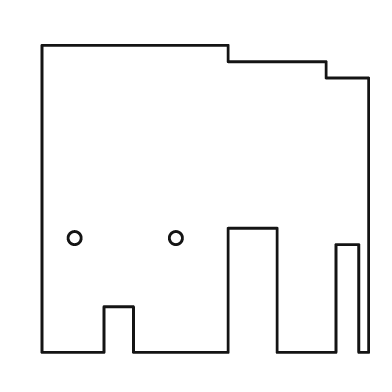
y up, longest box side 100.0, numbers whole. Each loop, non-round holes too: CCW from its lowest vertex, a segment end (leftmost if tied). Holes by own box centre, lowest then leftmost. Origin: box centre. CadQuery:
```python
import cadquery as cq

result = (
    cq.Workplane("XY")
    .moveTo(-50.0, -47.0)
    .lineTo(-31.0, -47.0)
    .lineTo(-31.0, -33.0)
    .lineTo(-22.0, -33.0)
    .lineTo(-22.0, -47.0)
    .lineTo(7.0, -47.0)
    .lineTo(7.0, -9.0)
    .lineTo(22.0, -9.0)
    .lineTo(22.0, -47.0)
    .lineTo(40.0, -47.0)
    .lineTo(40.0, -14.0)
    .lineTo(47.0, -14.0)
    .lineTo(47.0, -47.0)
    .lineTo(50.0, -47.0)
    .lineTo(50.0, 37.0)
    .lineTo(37.0, 37.0)
    .lineTo(37.0, 42.0)
    .lineTo(7.0, 42.0)
    .lineTo(7.0, 47.0)
    .lineTo(-50.0, 47.0)
    .close()
    .moveTo(-40.0, -12.0)
    .circle(2.0)
    .moveTo(-9.0, -12.0)
    .circle(2.0)
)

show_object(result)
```